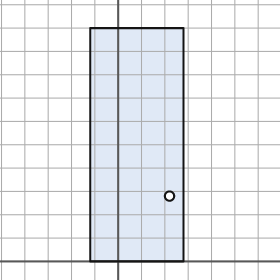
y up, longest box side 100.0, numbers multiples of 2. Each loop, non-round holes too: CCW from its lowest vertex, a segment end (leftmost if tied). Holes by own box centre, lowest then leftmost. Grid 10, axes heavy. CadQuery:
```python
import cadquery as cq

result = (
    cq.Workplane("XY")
    .moveTo(-12.0, 0.0)
    .lineTo(28.0, 0.0)
    .lineTo(28.0, 100.0)
    .lineTo(-12.0, 100.0)
    .close()
    .moveTo(22.0, 28.0)
    .circle(2.0)
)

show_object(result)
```